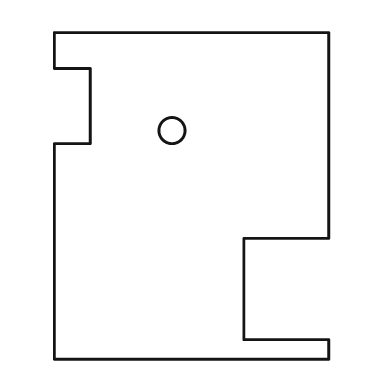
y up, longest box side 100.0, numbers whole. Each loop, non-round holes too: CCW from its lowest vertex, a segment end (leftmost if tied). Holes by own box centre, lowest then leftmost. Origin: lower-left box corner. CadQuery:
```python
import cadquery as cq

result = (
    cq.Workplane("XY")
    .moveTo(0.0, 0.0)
    .lineTo(84.0, 0.0)
    .lineTo(84.0, 6.0)
    .lineTo(58.0, 6.0)
    .lineTo(58.0, 37.0)
    .lineTo(84.0, 37.0)
    .lineTo(84.0, 100.0)
    .lineTo(0.0, 100.0)
    .lineTo(0.0, 89.0)
    .lineTo(11.0, 89.0)
    .lineTo(11.0, 66.0)
    .lineTo(0.0, 66.0)
    .close()
    .moveTo(36.0, 70.0)
    .circle(4.0)
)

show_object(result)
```